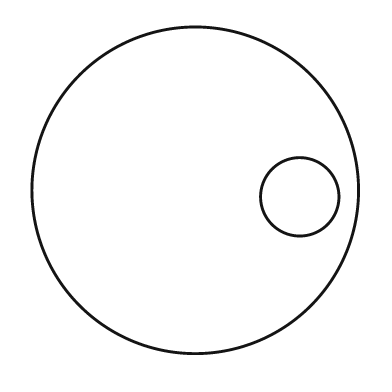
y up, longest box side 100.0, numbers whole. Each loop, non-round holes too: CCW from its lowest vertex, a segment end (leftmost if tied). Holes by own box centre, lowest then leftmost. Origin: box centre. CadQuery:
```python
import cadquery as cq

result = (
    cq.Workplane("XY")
    .moveTo(0.0, 0.0)
    .circle(50.0)
    .moveTo(32.0, -2.0)
    .circle(12.0)
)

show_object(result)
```